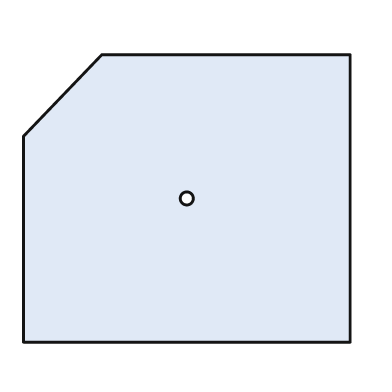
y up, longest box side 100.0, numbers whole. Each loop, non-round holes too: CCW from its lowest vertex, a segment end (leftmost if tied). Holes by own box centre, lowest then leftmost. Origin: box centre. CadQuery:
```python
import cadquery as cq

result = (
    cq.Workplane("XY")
    .moveTo(-50.0, -44.0)
    .lineTo(50.0, -44.0)
    .lineTo(50.0, 44.0)
    .lineTo(-26.0, 44.0)
    .lineTo(-50.0, 19.0)
    .close()
    .moveTo(0.0, 0.0)
    .circle(2.0)
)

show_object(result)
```